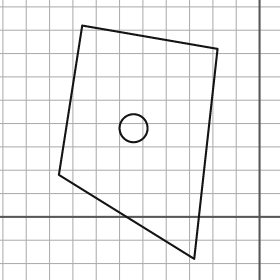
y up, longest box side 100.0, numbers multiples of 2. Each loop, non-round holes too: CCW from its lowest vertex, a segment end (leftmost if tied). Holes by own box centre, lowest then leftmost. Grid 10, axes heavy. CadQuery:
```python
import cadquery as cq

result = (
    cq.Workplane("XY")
    .moveTo(-28.0, -18.0)
    .lineTo(-18.0, 72.0)
    .lineTo(-76.0, 82.0)
    .lineTo(-86.0, 18.0)
    .close()
    .moveTo(-54.0, 38.0)
    .circle(6.0)
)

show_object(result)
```